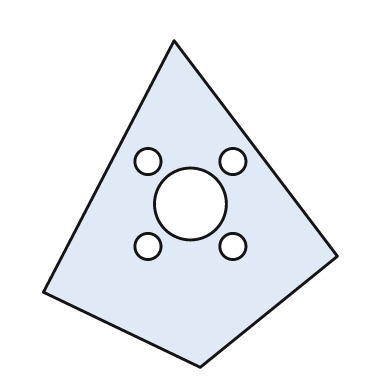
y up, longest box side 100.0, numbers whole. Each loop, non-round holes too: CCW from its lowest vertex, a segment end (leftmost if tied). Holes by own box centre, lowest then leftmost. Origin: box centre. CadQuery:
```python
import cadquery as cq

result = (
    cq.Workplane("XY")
    .moveTo(3.0, -50.0)
    .lineTo(45.0, -16.0)
    .lineTo(-5.0, 50.0)
    .lineTo(-45.0, -27.0)
    .close()
    .moveTo(-13.0, -13.0)
    .circle(4.0)
    .moveTo(13.0, -13.0)
    .circle(4.0)
    .moveTo(0.0, 0.0)
    .circle(11.0)
    .moveTo(-13.0, 13.0)
    .circle(4.0)
    .moveTo(13.0, 13.0)
    .circle(4.0)
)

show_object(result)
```